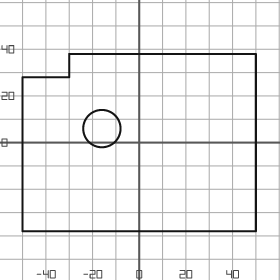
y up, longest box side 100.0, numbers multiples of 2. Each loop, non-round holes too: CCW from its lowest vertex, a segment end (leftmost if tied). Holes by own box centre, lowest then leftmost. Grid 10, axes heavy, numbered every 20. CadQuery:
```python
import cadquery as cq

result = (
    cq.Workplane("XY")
    .moveTo(-50.0, -38.0)
    .lineTo(50.0, -38.0)
    .lineTo(50.0, 38.0)
    .lineTo(-30.0, 38.0)
    .lineTo(-30.0, 28.0)
    .lineTo(-50.0, 28.0)
    .close()
    .moveTo(-16.0, 6.0)
    .circle(8.0)
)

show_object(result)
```